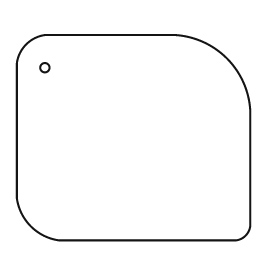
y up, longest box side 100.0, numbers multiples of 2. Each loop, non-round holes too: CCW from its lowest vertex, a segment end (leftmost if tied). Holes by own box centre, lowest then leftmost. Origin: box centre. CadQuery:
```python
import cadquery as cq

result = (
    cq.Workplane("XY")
    .moveTo(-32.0, -44.0)
    .lineTo(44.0, -44.0)
    .threePointArc((48.0, -42.0), (50.0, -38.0))
    .lineTo(50.0, 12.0)
    .threePointArc((40.0, 34.0), (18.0, 44.0))
    .lineTo(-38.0, 44.0)
    .threePointArc((-46.0, 40.0), (-50.0, 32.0))
    .lineTo(-50.0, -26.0)
    .threePointArc((-44.0, -38.0), (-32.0, -44.0))
    .close()
    .moveTo(-38.0, 30.0)
    .circle(2.0)
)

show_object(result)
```